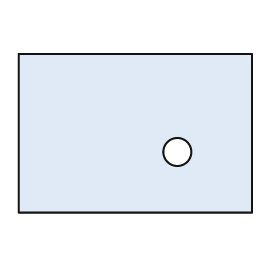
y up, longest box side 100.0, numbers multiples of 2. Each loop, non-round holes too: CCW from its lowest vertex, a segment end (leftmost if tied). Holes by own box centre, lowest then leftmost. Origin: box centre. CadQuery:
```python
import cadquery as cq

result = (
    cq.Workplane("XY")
    .moveTo(-50.0, -34.0)
    .lineTo(50.0, -34.0)
    .lineTo(50.0, 34.0)
    .lineTo(-50.0, 34.0)
    .close()
    .moveTo(18.0, -8.0)
    .circle(6.0)
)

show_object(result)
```